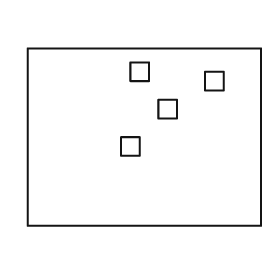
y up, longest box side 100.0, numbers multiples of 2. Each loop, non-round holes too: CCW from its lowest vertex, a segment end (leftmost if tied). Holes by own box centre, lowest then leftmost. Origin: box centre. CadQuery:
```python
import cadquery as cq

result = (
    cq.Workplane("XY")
    .moveTo(-50.0, -38.0)
    .lineTo(50.0, -38.0)
    .lineTo(50.0, 38.0)
    .lineTo(-50.0, 38.0)
    .close()
    .moveTo(-10.0, -8.0)
    .lineTo(-2.0, -8.0)
    .lineTo(-2.0, 0.0)
    .lineTo(-10.0, 0.0)
    .close()
    .moveTo(6.0, 8.0)
    .lineTo(14.0, 8.0)
    .lineTo(14.0, 16.0)
    .lineTo(6.0, 16.0)
    .close()
    .moveTo(26.0, 20.0)
    .lineTo(34.0, 20.0)
    .lineTo(34.0, 28.0)
    .lineTo(26.0, 28.0)
    .close()
    .moveTo(-6.0, 24.0)
    .lineTo(2.0, 24.0)
    .lineTo(2.0, 32.0)
    .lineTo(-6.0, 32.0)
    .close()
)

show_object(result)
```